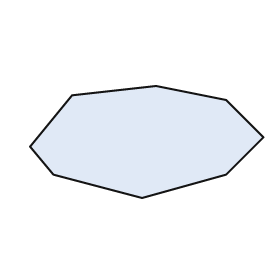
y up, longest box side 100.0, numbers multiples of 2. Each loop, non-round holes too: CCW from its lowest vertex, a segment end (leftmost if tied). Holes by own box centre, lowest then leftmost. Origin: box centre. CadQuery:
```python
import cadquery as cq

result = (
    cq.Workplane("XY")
    .moveTo(-2.0, -24.0)
    .lineTo(34.0, -14.0)
    .lineTo(50.0, 2.0)
    .lineTo(34.0, 18.0)
    .lineTo(4.0, 24.0)
    .lineTo(-32.0, 20.0)
    .lineTo(-50.0, -2.0)
    .lineTo(-40.0, -14.0)
    .close()
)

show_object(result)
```